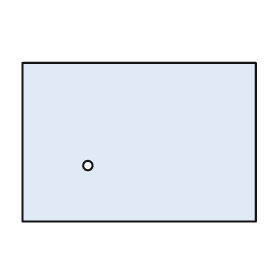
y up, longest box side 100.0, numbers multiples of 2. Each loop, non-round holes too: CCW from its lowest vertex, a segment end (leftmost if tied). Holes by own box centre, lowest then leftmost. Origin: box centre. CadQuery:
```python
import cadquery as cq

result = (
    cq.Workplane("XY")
    .moveTo(-50.0, -34.0)
    .lineTo(50.0, -34.0)
    .lineTo(50.0, 34.0)
    .lineTo(-50.0, 34.0)
    .close()
    .moveTo(-22.0, -10.0)
    .circle(2.0)
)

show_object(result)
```